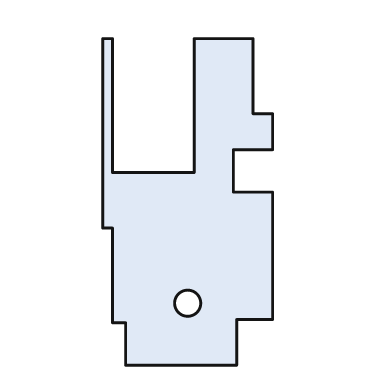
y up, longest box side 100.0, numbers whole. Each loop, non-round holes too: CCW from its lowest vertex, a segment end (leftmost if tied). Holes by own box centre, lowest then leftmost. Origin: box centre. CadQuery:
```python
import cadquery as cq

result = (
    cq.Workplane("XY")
    .moveTo(-19.0, -50.0)
    .lineTo(15.0, -50.0)
    .lineTo(15.0, -36.0)
    .lineTo(26.0, -36.0)
    .lineTo(26.0, 3.0)
    .lineTo(14.0, 3.0)
    .lineTo(14.0, 16.0)
    .lineTo(26.0, 16.0)
    .lineTo(26.0, 27.0)
    .lineTo(20.0, 27.0)
    .lineTo(20.0, 50.0)
    .lineTo(2.0, 50.0)
    .lineTo(2.0, 9.0)
    .lineTo(-23.0, 9.0)
    .lineTo(-23.0, 50.0)
    .lineTo(-26.0, 50.0)
    .lineTo(-26.0, -8.0)
    .lineTo(-23.0, -8.0)
    .lineTo(-23.0, -37.0)
    .lineTo(-19.0, -37.0)
    .close()
    .moveTo(0.0, -31.0)
    .circle(4.0)
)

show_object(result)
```